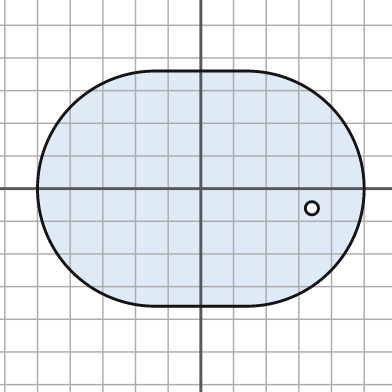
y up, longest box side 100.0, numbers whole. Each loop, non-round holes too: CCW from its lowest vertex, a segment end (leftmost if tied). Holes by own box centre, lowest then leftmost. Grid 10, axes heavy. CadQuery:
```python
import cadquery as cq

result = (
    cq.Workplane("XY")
    .moveTo(-14.0, -36.0)
    .lineTo(14.0, -36.0)
    .threePointArc((50.0, 0.0), (14.0, 36.0))
    .lineTo(-14.0, 36.0)
    .threePointArc((-50.0, 0.0), (-14.0, -36.0))
    .close()
    .moveTo(34.0, -6.0)
    .circle(2.0)
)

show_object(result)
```